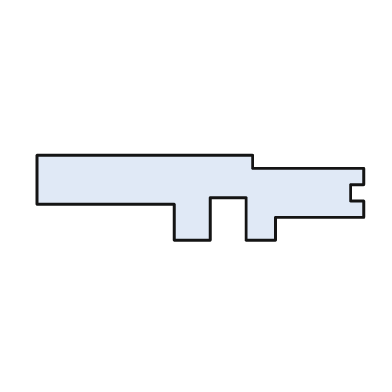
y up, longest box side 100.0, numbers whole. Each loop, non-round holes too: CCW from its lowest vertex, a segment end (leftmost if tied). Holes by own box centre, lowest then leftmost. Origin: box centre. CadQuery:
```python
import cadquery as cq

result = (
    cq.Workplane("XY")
    .moveTo(-8.0, -13.0)
    .lineTo(3.0, -13.0)
    .lineTo(3.0, 0.0)
    .lineTo(14.0, 0.0)
    .lineTo(14.0, -13.0)
    .lineTo(23.0, -13.0)
    .lineTo(23.0, -6.0)
    .lineTo(50.0, -6.0)
    .lineTo(50.0, -1.0)
    .lineTo(46.0, -1.0)
    .lineTo(46.0, 4.0)
    .lineTo(50.0, 4.0)
    .lineTo(50.0, 9.0)
    .lineTo(16.0, 9.0)
    .lineTo(16.0, 13.0)
    .lineTo(-50.0, 13.0)
    .lineTo(-50.0, -2.0)
    .lineTo(-8.0, -2.0)
    .close()
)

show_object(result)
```